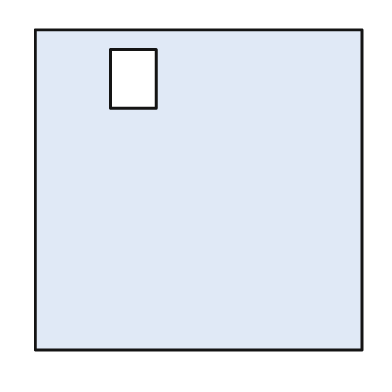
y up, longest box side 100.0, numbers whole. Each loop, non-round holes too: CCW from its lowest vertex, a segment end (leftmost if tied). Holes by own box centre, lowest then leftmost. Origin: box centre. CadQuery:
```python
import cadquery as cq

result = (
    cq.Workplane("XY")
    .moveTo(-50.0, -49.0)
    .lineTo(50.0, -49.0)
    .lineTo(50.0, 49.0)
    .lineTo(-50.0, 49.0)
    .close()
    .moveTo(-27.0, 25.0)
    .lineTo(-13.0, 25.0)
    .lineTo(-13.0, 43.0)
    .lineTo(-27.0, 43.0)
    .close()
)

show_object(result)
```